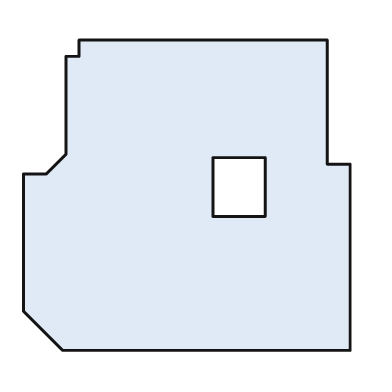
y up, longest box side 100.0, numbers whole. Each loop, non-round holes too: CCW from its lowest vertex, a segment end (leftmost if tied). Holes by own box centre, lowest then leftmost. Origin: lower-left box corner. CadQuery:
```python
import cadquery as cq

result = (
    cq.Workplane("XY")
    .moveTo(12.0, 0.0)
    .lineTo(100.0, 0.0)
    .lineTo(100.0, 57.0)
    .lineTo(93.0, 57.0)
    .lineTo(93.0, 95.0)
    .lineTo(17.0, 95.0)
    .lineTo(17.0, 90.0)
    .lineTo(13.0, 90.0)
    .lineTo(13.0, 60.0)
    .lineTo(7.0, 54.0)
    .lineTo(0.0, 54.0)
    .lineTo(0.0, 12.0)
    .close()
    .moveTo(58.0, 41.0)
    .lineTo(74.0, 41.0)
    .lineTo(74.0, 59.0)
    .lineTo(58.0, 59.0)
    .close()
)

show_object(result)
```